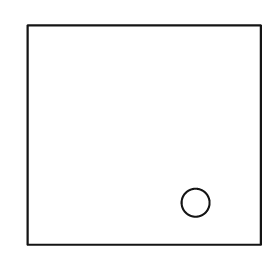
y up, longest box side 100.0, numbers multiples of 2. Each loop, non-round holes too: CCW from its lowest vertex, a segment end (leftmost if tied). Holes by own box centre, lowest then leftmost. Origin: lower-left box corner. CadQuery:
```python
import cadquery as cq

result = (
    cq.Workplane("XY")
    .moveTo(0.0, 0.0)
    .lineTo(100.0, 0.0)
    .lineTo(100.0, 94.0)
    .lineTo(0.0, 94.0)
    .close()
    .moveTo(72.0, 18.0)
    .circle(6.0)
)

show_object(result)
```